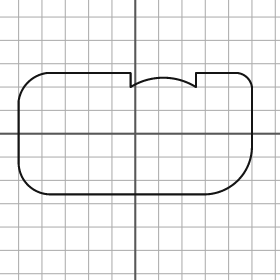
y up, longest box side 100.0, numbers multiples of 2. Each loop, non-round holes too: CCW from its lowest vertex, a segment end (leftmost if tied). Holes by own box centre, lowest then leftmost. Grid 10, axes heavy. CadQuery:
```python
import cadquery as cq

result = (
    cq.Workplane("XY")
    .moveTo(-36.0, -26.0)
    .lineTo(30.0, -26.0)
    .threePointArc((44.0, -20.0), (50.0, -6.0))
    .lineTo(50.0, 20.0)
    .threePointArc((48.0, 24.0), (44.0, 26.0))
    .lineTo(26.0, 26.0)
    .lineTo(26.0, 20.0)
    .threePointArc((12.0, 24.0), (-2.0, 20.0))
    .lineTo(-2.0, 26.0)
    .lineTo(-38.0, 26.0)
    .threePointArc((-46.0, 22.0), (-50.0, 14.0))
    .lineTo(-50.0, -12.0)
    .threePointArc((-46.0, -22.0), (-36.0, -26.0))
    .close()
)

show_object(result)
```